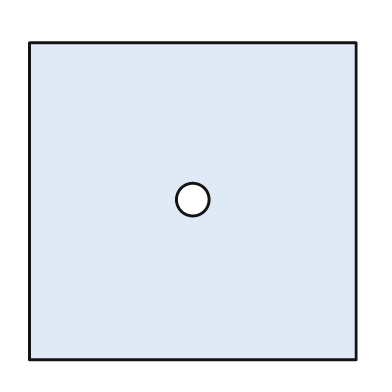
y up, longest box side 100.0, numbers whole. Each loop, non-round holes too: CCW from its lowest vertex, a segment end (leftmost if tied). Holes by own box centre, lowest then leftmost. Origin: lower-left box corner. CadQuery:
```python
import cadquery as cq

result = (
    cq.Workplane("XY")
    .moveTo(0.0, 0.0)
    .lineTo(100.0, 0.0)
    .lineTo(100.0, 97.0)
    .lineTo(0.0, 97.0)
    .close()
    .moveTo(50.0, 49.0)
    .circle(5.0)
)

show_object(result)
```